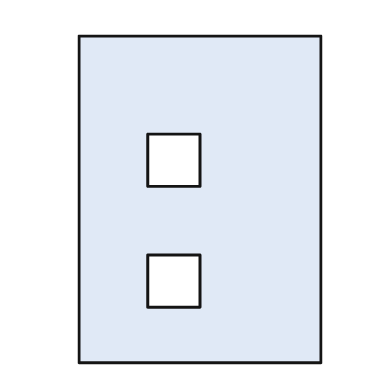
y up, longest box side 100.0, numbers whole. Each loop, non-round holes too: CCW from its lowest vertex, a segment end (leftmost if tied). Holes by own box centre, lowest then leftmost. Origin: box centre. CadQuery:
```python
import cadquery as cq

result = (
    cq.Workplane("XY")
    .moveTo(-37.0, -50.0)
    .lineTo(37.0, -50.0)
    .lineTo(37.0, 50.0)
    .lineTo(-37.0, 50.0)
    .close()
    .moveTo(-16.0, -33.0)
    .lineTo(0.0, -33.0)
    .lineTo(0.0, -17.0)
    .lineTo(-16.0, -17.0)
    .close()
    .moveTo(-16.0, 4.0)
    .lineTo(0.0, 4.0)
    .lineTo(0.0, 20.0)
    .lineTo(-16.0, 20.0)
    .close()
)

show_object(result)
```